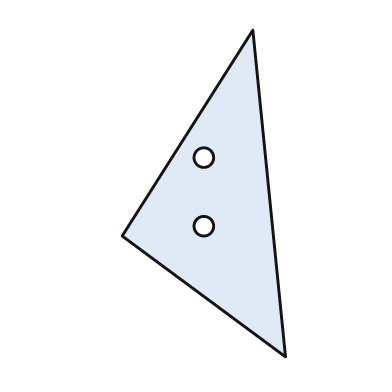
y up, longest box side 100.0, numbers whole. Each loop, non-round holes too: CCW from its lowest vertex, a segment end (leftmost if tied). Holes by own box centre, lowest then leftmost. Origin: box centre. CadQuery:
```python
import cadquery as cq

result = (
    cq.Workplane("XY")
    .moveTo(25.0, -50.0)
    .lineTo(15.0, 50.0)
    .lineTo(-25.0, -13.0)
    .close()
    .moveTo(0.0, -10.0)
    .circle(3.0)
    .moveTo(0.0, 11.0)
    .circle(3.0)
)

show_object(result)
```